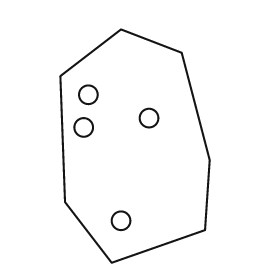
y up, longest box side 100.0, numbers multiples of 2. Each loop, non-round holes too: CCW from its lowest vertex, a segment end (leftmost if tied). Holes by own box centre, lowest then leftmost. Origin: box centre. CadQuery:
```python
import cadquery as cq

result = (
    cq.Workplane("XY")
    .moveTo(-10.0, -50.0)
    .lineTo(30.0, -36.0)
    .lineTo(32.0, -6.0)
    .lineTo(20.0, 40.0)
    .lineTo(-6.0, 50.0)
    .lineTo(-32.0, 30.0)
    .lineTo(-30.0, -24.0)
    .close()
    .moveTo(-6.0, -32.0)
    .circle(4.0)
    .moveTo(-22.0, 8.0)
    .circle(4.0)
    .moveTo(6.0, 12.0)
    .circle(4.0)
    .moveTo(-20.0, 22.0)
    .circle(4.0)
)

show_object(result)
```